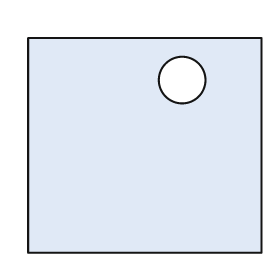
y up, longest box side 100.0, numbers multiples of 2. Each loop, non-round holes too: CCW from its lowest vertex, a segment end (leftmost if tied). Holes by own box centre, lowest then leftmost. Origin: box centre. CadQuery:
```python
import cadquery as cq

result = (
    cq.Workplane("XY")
    .moveTo(-50.0, -46.0)
    .lineTo(50.0, -46.0)
    .lineTo(50.0, 46.0)
    .lineTo(-50.0, 46.0)
    .close()
    .moveTo(16.0, 28.0)
    .circle(10.0)
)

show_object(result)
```